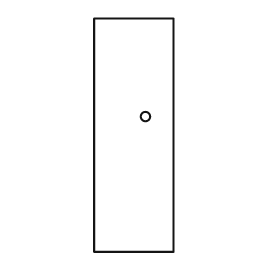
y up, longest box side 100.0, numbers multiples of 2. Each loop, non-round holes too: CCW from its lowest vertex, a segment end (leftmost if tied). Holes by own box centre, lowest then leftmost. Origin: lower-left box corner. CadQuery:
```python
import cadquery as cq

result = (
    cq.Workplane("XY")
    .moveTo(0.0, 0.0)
    .lineTo(34.0, 0.0)
    .lineTo(34.0, 100.0)
    .lineTo(0.0, 100.0)
    .close()
    .moveTo(22.0, 58.0)
    .circle(2.0)
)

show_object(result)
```